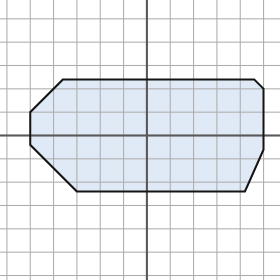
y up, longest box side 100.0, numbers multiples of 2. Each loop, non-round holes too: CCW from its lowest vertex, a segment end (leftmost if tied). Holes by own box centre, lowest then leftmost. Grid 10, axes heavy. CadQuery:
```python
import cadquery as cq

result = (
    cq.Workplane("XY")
    .moveTo(-30.0, -24.0)
    .lineTo(42.0, -24.0)
    .lineTo(50.0, -6.0)
    .lineTo(50.0, 20.0)
    .lineTo(46.0, 24.0)
    .lineTo(-36.0, 24.0)
    .lineTo(-50.0, 10.0)
    .lineTo(-50.0, -4.0)
    .close()
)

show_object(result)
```